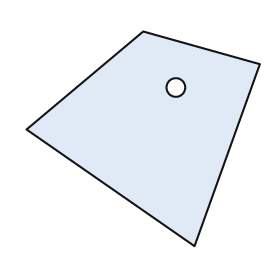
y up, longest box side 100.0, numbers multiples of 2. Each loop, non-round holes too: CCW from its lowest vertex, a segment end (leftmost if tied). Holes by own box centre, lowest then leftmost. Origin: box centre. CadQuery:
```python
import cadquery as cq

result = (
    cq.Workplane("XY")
    .moveTo(22.0, -46.0)
    .lineTo(50.0, 32.0)
    .lineTo(0.0, 46.0)
    .lineTo(-50.0, 4.0)
    .close()
    .moveTo(14.0, 22.0)
    .circle(4.0)
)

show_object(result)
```